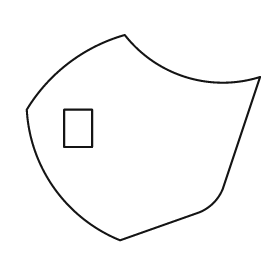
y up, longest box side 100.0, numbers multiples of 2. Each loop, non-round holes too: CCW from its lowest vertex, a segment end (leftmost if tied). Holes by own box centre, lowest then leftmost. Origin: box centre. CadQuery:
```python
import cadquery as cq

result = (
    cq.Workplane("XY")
    .moveTo(-10.0, -44.0)
    .lineTo(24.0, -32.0)
    .threePointArc((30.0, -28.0), (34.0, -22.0))
    .lineTo(50.0, 26.0)
    .threePointArc((18.0, 26.0), (-8.0, 44.0))
    .threePointArc((-32.0, 32.0), (-50.0, 12.0))
    .threePointArc((-38.0, -22.0), (-10.0, -44.0))
    .close()
    .moveTo(-34.0, -4.0)
    .lineTo(-22.0, -4.0)
    .lineTo(-22.0, 12.0)
    .lineTo(-34.0, 12.0)
    .close()
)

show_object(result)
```